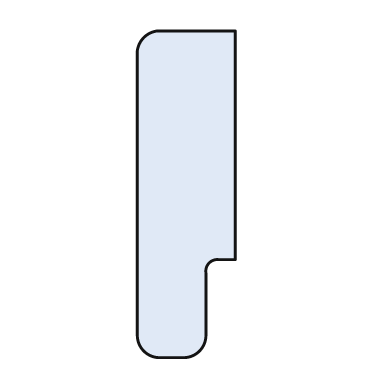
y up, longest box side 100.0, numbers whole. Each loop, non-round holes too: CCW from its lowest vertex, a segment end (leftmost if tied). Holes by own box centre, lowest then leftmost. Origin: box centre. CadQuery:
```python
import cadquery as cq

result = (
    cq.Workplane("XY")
    .moveTo(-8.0, -50.0)
    .lineTo(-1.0, -50.0)
    .threePointArc((4.0, -48.0), (6.0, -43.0))
    .lineTo(6.0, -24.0)
    .threePointArc((7.0, -21.0), (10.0, -20.0))
    .lineTo(15.0, -20.0)
    .lineTo(15.0, 50.0)
    .lineTo(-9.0, 50.0)
    .threePointArc((-13.0, 48.0), (-15.0, 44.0))
    .lineTo(-15.0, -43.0)
    .threePointArc((-13.0, -48.0), (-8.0, -50.0))
    .close()
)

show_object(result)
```